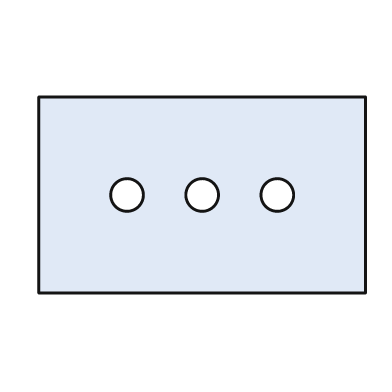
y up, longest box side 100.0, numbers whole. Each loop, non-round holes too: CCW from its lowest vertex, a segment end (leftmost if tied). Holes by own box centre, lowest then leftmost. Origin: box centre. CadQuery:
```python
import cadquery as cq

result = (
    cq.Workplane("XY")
    .moveTo(-50.0, -30.0)
    .lineTo(50.0, -30.0)
    .lineTo(50.0, 30.0)
    .lineTo(-50.0, 30.0)
    .close()
    .moveTo(-23.0, 0.0)
    .circle(5.0)
    .moveTo(0.0, 0.0)
    .circle(5.0)
    .moveTo(23.0, 0.0)
    .circle(5.0)
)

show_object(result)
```